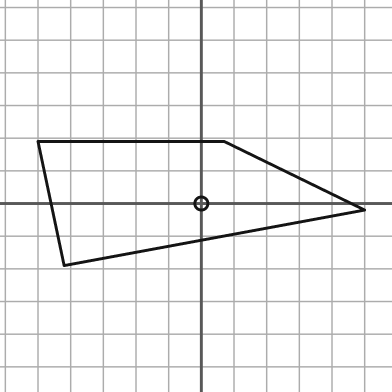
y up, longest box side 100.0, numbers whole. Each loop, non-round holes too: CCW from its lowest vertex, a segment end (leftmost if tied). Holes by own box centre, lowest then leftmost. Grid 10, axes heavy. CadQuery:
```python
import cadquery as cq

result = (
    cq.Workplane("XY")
    .moveTo(-42.0, -19.0)
    .lineTo(50.0, -2.0)
    .lineTo(7.0, 19.0)
    .lineTo(-50.0, 19.0)
    .close()
    .moveTo(0.0, 0.0)
    .circle(2.0)
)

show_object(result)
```